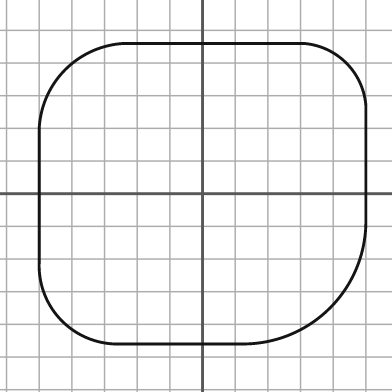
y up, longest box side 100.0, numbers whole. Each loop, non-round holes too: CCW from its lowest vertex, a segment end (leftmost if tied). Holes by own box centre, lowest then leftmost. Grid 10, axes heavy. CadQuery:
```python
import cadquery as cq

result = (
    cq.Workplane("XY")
    .moveTo(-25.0, -46.0)
    .lineTo(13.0, -46.0)
    .threePointArc((39.0, -35.0), (50.0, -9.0))
    .lineTo(50.0, 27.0)
    .threePointArc((44.0, 40.0), (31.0, 46.0))
    .lineTo(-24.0, 46.0)
    .threePointArc((-42.0, 38.0), (-50.0, 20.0))
    .lineTo(-50.0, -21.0)
    .threePointArc((-43.0, -39.0), (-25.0, -46.0))
    .close()
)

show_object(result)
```